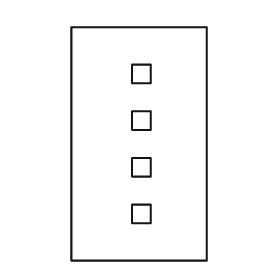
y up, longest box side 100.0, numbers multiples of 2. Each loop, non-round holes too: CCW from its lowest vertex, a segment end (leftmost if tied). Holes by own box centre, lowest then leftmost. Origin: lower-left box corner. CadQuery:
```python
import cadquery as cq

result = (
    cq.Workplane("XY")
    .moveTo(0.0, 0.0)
    .lineTo(58.0, 0.0)
    .lineTo(58.0, 100.0)
    .lineTo(0.0, 100.0)
    .close()
    .moveTo(26.0, 16.0)
    .lineTo(34.0, 16.0)
    .lineTo(34.0, 24.0)
    .lineTo(26.0, 24.0)
    .close()
    .moveTo(26.0, 36.0)
    .lineTo(34.0, 36.0)
    .lineTo(34.0, 44.0)
    .lineTo(26.0, 44.0)
    .close()
    .moveTo(26.0, 56.0)
    .lineTo(34.0, 56.0)
    .lineTo(34.0, 64.0)
    .lineTo(26.0, 64.0)
    .close()
    .moveTo(26.0, 76.0)
    .lineTo(34.0, 76.0)
    .lineTo(34.0, 84.0)
    .lineTo(26.0, 84.0)
    .close()
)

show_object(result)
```